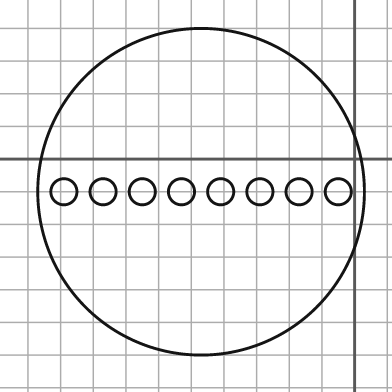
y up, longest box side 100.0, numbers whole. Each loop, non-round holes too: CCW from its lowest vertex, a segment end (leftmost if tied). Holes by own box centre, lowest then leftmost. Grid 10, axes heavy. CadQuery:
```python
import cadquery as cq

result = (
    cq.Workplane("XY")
    .moveTo(-47.0, -10.0)
    .circle(50.0)
    .moveTo(-89.0, -10.0)
    .circle(4.0)
    .moveTo(-77.0, -10.0)
    .circle(4.0)
    .moveTo(-65.0, -10.0)
    .circle(4.0)
    .moveTo(-53.0, -10.0)
    .circle(4.0)
    .moveTo(-41.0, -10.0)
    .circle(4.0)
    .moveTo(-29.0, -10.0)
    .circle(4.0)
    .moveTo(-17.0, -10.0)
    .circle(4.0)
    .moveTo(-5.0, -10.0)
    .circle(4.0)
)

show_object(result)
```